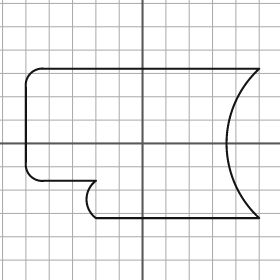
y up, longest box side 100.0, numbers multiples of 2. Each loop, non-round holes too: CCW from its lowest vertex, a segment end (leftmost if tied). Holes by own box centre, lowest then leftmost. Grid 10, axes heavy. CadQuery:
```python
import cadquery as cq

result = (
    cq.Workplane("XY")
    .moveTo(-20.0, -32.0)
    .lineTo(50.0, -32.0)
    .threePointArc((36.0, 0.0), (50.0, 32.0))
    .lineTo(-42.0, 32.0)
    .threePointArc((-48.0, 30.0), (-50.0, 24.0))
    .lineTo(-50.0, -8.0)
    .threePointArc((-48.0, -14.0), (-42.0, -16.0))
    .lineTo(-20.0, -16.0)
    .threePointArc((-24.0, -24.0), (-20.0, -32.0))
    .close()
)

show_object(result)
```